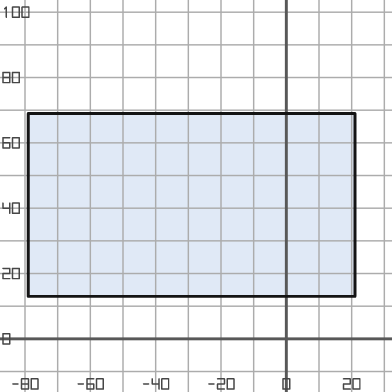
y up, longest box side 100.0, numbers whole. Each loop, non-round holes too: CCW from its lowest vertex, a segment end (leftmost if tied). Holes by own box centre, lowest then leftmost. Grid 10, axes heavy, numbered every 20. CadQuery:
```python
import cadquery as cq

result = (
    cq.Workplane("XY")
    .moveTo(-79.0, 13.0)
    .lineTo(21.0, 13.0)
    .lineTo(21.0, 69.0)
    .lineTo(-79.0, 69.0)
    .close()
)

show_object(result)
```